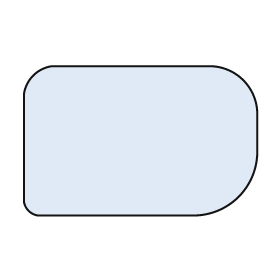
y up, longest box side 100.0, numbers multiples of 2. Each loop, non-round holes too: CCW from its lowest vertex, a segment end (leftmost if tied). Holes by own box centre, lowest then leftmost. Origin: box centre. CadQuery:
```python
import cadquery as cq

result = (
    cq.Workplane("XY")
    .moveTo(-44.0, -32.0)
    .lineTo(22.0, -32.0)
    .threePointArc((42.0, -24.0), (50.0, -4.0))
    .lineTo(50.0, 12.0)
    .threePointArc((44.0, 26.0), (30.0, 32.0))
    .lineTo(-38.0, 32.0)
    .threePointArc((-46.0, 28.0), (-50.0, 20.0))
    .lineTo(-50.0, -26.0)
    .threePointArc((-48.0, -30.0), (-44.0, -32.0))
    .close()
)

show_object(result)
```